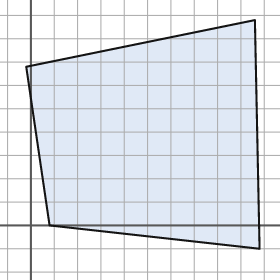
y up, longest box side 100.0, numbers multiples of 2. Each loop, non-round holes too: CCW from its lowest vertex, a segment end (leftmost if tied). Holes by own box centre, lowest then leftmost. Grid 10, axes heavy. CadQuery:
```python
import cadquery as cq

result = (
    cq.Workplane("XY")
    .moveTo(98.0, -10.0)
    .lineTo(96.0, 88.0)
    .lineTo(-2.0, 68.0)
    .lineTo(8.0, 0.0)
    .close()
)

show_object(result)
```